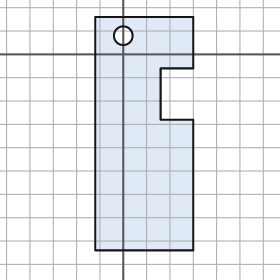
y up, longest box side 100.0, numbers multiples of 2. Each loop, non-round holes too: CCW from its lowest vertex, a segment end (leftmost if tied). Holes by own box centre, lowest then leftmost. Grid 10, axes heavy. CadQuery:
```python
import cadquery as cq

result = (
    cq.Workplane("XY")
    .moveTo(-12.0, -84.0)
    .lineTo(30.0, -84.0)
    .lineTo(30.0, -28.0)
    .lineTo(16.0, -28.0)
    .lineTo(16.0, -6.0)
    .lineTo(30.0, -6.0)
    .lineTo(30.0, 16.0)
    .lineTo(-12.0, 16.0)
    .close()
    .moveTo(0.0, 8.0)
    .circle(4.0)
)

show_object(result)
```